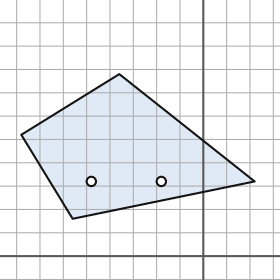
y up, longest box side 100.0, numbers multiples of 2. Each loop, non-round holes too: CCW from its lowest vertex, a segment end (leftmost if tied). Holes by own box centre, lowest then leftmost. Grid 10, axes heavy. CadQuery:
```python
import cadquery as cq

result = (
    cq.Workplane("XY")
    .moveTo(-56.0, 16.0)
    .lineTo(22.0, 32.0)
    .lineTo(-36.0, 78.0)
    .lineTo(-78.0, 52.0)
    .close()
    .moveTo(-48.0, 32.0)
    .circle(2.0)
    .moveTo(-18.0, 32.0)
    .circle(2.0)
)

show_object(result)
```